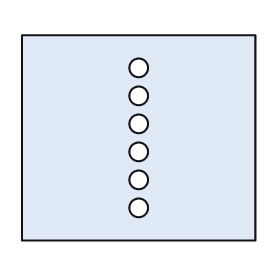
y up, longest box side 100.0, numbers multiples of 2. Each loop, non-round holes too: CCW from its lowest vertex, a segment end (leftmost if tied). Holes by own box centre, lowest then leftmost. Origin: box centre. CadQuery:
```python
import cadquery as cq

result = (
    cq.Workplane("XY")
    .moveTo(-50.0, -44.0)
    .lineTo(50.0, -44.0)
    .lineTo(50.0, 44.0)
    .lineTo(-50.0, 44.0)
    .close()
    .moveTo(0.0, -30.0)
    .circle(4.0)
    .moveTo(0.0, -18.0)
    .circle(4.0)
    .moveTo(0.0, -6.0)
    .circle(4.0)
    .moveTo(0.0, 6.0)
    .circle(4.0)
    .moveTo(0.0, 18.0)
    .circle(4.0)
    .moveTo(0.0, 30.0)
    .circle(4.0)
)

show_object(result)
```